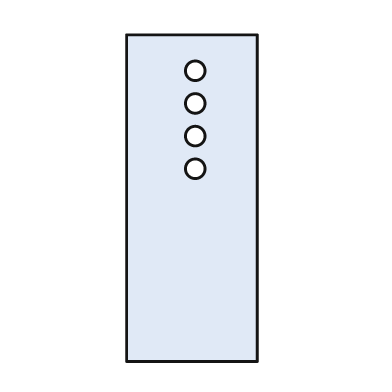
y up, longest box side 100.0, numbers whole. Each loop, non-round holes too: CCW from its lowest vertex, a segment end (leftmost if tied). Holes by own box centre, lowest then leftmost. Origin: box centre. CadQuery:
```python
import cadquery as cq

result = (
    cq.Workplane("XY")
    .moveTo(-20.0, -50.0)
    .lineTo(20.0, -50.0)
    .lineTo(20.0, 50.0)
    .lineTo(-20.0, 50.0)
    .close()
    .moveTo(1.0, 9.0)
    .circle(3.0)
    .moveTo(1.0, 19.0)
    .circle(3.0)
    .moveTo(1.0, 29.0)
    .circle(3.0)
    .moveTo(1.0, 39.0)
    .circle(3.0)
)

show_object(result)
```